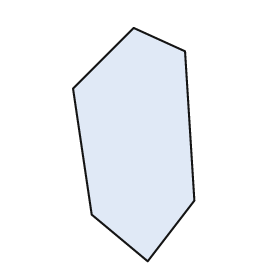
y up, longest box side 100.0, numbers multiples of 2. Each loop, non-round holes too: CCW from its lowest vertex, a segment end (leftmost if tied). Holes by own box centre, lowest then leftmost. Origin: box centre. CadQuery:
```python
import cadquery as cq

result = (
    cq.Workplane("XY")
    .moveTo(6.0, -50.0)
    .lineTo(26.0, -24.0)
    .lineTo(22.0, 40.0)
    .lineTo(0.0, 50.0)
    .lineTo(-26.0, 24.0)
    .lineTo(-18.0, -30.0)
    .close()
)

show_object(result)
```